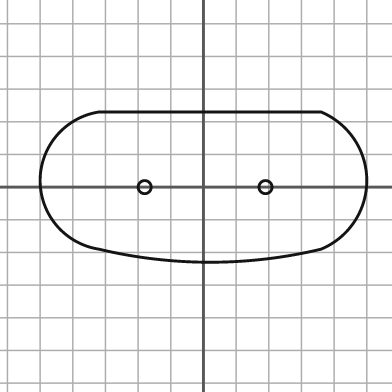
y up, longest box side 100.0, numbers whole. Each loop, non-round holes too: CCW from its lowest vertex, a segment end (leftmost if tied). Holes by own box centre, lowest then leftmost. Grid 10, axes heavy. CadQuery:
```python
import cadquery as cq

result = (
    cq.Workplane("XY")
    .moveTo(-32.0, -19.0)
    .threePointArc((2.0, -23.0), (36.0, -19.0))
    .threePointArc((50.0, 2.0), (36.0, 23.0))
    .lineTo(-32.0, 23.0)
    .threePointArc((-50.0, 2.0), (-32.0, -19.0))
    .close()
    .moveTo(-18.0, 0.0)
    .circle(2.0)
    .moveTo(19.0, 0.0)
    .circle(2.0)
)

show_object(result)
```